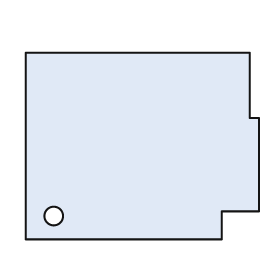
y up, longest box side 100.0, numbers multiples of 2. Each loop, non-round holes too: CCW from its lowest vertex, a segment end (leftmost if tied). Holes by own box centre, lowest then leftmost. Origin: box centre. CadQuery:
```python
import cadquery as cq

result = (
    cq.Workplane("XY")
    .moveTo(-50.0, -40.0)
    .lineTo(34.0, -40.0)
    .lineTo(34.0, -28.0)
    .lineTo(50.0, -28.0)
    .lineTo(50.0, 12.0)
    .lineTo(46.0, 12.0)
    .lineTo(46.0, 40.0)
    .lineTo(-50.0, 40.0)
    .close()
    .moveTo(-38.0, -30.0)
    .circle(4.0)
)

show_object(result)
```